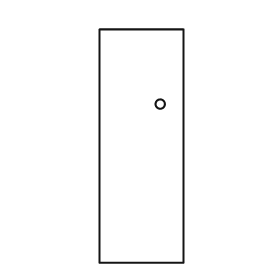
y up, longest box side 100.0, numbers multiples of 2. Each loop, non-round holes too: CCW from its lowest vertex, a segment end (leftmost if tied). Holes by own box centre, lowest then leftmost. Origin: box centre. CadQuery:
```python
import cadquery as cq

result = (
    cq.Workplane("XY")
    .moveTo(-18.0, -50.0)
    .lineTo(18.0, -50.0)
    .lineTo(18.0, 50.0)
    .lineTo(-18.0, 50.0)
    .close()
    .moveTo(8.0, 18.0)
    .circle(2.0)
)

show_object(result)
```